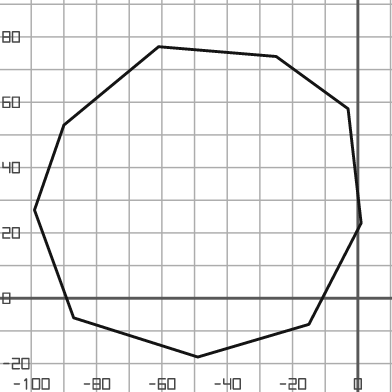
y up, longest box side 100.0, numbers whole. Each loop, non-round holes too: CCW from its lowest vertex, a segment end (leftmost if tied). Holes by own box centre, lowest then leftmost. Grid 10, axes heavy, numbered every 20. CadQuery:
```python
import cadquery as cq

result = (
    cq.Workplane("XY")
    .moveTo(-49.0, -18.0)
    .lineTo(-15.0, -8.0)
    .lineTo(1.0, 23.0)
    .lineTo(-3.0, 58.0)
    .lineTo(-25.0, 74.0)
    .lineTo(-61.0, 77.0)
    .lineTo(-90.0, 53.0)
    .lineTo(-99.0, 27.0)
    .lineTo(-87.0, -6.0)
    .close()
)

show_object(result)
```